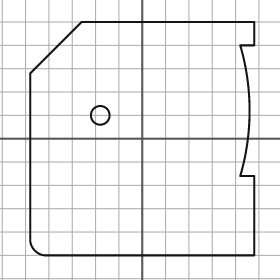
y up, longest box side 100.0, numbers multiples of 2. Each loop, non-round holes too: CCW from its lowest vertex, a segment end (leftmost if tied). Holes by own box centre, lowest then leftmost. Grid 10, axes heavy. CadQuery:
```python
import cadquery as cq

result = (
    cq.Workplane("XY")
    .moveTo(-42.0, -50.0)
    .lineTo(48.0, -50.0)
    .lineTo(48.0, -16.0)
    .lineTo(42.0, -16.0)
    .threePointArc((46.0, 12.0), (42.0, 40.0))
    .lineTo(48.0, 40.0)
    .lineTo(48.0, 50.0)
    .lineTo(-26.0, 50.0)
    .lineTo(-48.0, 28.0)
    .lineTo(-48.0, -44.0)
    .threePointArc((-46.0, -48.0), (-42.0, -50.0))
    .close()
    .moveTo(-18.0, 10.0)
    .circle(4.0)
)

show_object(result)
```